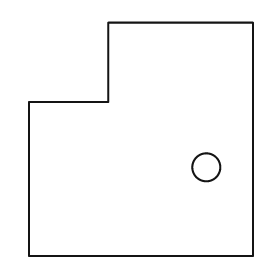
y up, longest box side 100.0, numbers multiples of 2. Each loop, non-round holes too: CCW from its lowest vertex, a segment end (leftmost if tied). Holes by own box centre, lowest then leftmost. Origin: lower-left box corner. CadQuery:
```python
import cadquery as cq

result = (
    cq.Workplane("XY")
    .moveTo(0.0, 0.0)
    .lineTo(96.0, 0.0)
    .lineTo(96.0, 100.0)
    .lineTo(34.0, 100.0)
    .lineTo(34.0, 66.0)
    .lineTo(0.0, 66.0)
    .close()
    .moveTo(76.0, 38.0)
    .circle(6.0)
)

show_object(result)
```